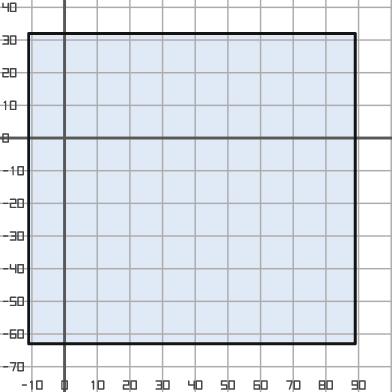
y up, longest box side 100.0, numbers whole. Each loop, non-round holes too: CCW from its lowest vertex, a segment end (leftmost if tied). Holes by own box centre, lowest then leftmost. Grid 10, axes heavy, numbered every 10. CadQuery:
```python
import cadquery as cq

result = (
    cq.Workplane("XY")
    .moveTo(-11.0, -63.0)
    .lineTo(89.0, -63.0)
    .lineTo(89.0, 32.0)
    .lineTo(-11.0, 32.0)
    .close()
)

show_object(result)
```